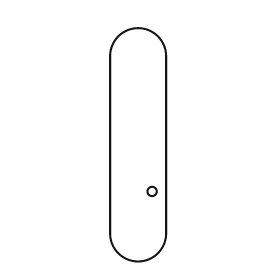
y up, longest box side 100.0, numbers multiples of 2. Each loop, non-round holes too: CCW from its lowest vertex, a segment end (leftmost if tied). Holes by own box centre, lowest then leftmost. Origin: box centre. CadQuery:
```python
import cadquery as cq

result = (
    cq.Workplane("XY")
    .moveTo(-12.0, -38.0)
    .threePointArc((0.0, -50.0), (12.0, -38.0))
    .lineTo(12.0, 38.0)
    .threePointArc((0.0, 50.0), (-12.0, 38.0))
    .close()
    .moveTo(6.0, -20.0)
    .circle(2.0)
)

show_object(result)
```